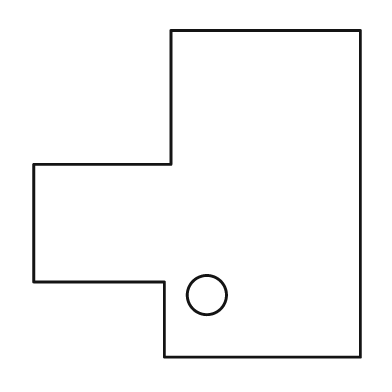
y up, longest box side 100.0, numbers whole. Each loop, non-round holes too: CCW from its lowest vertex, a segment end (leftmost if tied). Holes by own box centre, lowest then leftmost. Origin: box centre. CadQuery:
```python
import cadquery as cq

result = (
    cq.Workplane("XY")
    .moveTo(-10.0, -50.0)
    .lineTo(50.0, -50.0)
    .lineTo(50.0, 50.0)
    .lineTo(-8.0, 50.0)
    .lineTo(-8.0, 9.0)
    .lineTo(-50.0, 9.0)
    .lineTo(-50.0, -27.0)
    .lineTo(-10.0, -27.0)
    .close()
    .moveTo(3.0, -31.0)
    .circle(6.0)
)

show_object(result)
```